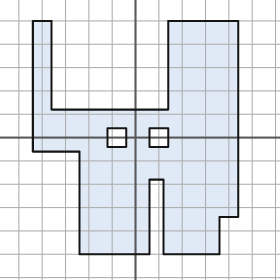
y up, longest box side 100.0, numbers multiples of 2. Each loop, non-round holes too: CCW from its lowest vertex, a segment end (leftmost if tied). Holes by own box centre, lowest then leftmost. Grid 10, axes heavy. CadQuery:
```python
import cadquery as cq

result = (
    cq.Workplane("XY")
    .moveTo(-24.0, -50.0)
    .lineTo(6.0, -50.0)
    .lineTo(6.0, -18.0)
    .lineTo(12.0, -18.0)
    .lineTo(12.0, -50.0)
    .lineTo(36.0, -50.0)
    .lineTo(36.0, -34.0)
    .lineTo(44.0, -34.0)
    .lineTo(44.0, 50.0)
    .lineTo(14.0, 50.0)
    .lineTo(14.0, 12.0)
    .lineTo(-36.0, 12.0)
    .lineTo(-36.0, 50.0)
    .lineTo(-44.0, 50.0)
    .lineTo(-44.0, -6.0)
    .lineTo(-24.0, -6.0)
    .close()
    .moveTo(-12.0, -4.0)
    .lineTo(-4.0, -4.0)
    .lineTo(-4.0, 4.0)
    .lineTo(-12.0, 4.0)
    .close()
    .moveTo(6.0, -4.0)
    .lineTo(14.0, -4.0)
    .lineTo(14.0, 4.0)
    .lineTo(6.0, 4.0)
    .close()
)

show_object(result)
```